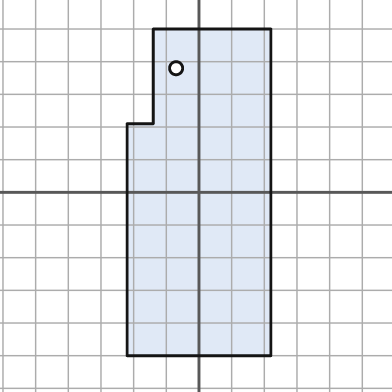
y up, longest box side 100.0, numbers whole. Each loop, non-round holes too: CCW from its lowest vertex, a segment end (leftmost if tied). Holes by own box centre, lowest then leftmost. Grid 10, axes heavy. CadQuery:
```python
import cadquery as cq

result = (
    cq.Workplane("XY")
    .moveTo(-22.0, -50.0)
    .lineTo(22.0, -50.0)
    .lineTo(22.0, 50.0)
    .lineTo(-14.0, 50.0)
    .lineTo(-14.0, 21.0)
    .lineTo(-22.0, 21.0)
    .close()
    .moveTo(-7.0, 38.0)
    .circle(2.0)
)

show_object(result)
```